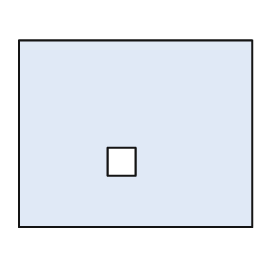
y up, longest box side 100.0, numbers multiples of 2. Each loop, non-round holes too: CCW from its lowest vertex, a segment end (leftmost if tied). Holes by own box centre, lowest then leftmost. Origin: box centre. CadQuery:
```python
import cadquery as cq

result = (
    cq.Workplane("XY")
    .moveTo(-50.0, -40.0)
    .lineTo(50.0, -40.0)
    .lineTo(50.0, 40.0)
    .lineTo(-50.0, 40.0)
    .close()
    .moveTo(-12.0, -18.0)
    .lineTo(0.0, -18.0)
    .lineTo(0.0, -6.0)
    .lineTo(-12.0, -6.0)
    .close()
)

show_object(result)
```